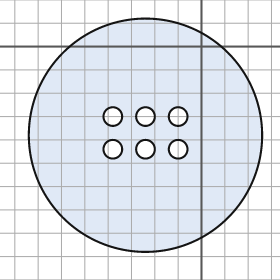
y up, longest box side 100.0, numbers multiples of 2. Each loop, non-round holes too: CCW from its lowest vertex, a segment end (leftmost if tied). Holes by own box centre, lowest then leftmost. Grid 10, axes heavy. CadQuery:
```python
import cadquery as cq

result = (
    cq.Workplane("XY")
    .moveTo(-24.0, -38.0)
    .circle(50.0)
    .moveTo(-38.0, -44.0)
    .circle(4.0)
    .moveTo(-24.0, -44.0)
    .circle(4.0)
    .moveTo(-10.0, -44.0)
    .circle(4.0)
    .moveTo(-38.0, -30.0)
    .circle(4.0)
    .moveTo(-24.0, -30.0)
    .circle(4.0)
    .moveTo(-10.0, -30.0)
    .circle(4.0)
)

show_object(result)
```